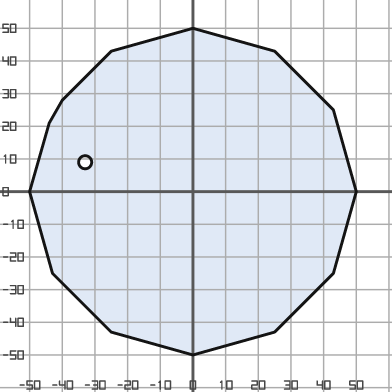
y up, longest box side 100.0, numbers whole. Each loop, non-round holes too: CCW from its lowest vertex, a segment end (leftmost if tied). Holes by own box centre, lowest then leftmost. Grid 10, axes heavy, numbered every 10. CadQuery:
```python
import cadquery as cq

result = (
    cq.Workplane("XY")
    .moveTo(0.0, -50.0)
    .lineTo(25.0, -43.0)
    .lineTo(43.0, -25.0)
    .lineTo(50.0, 0.0)
    .lineTo(43.0, 25.0)
    .lineTo(25.0, 43.0)
    .lineTo(0.0, 50.0)
    .lineTo(-25.0, 43.0)
    .lineTo(-40.0, 28.0)
    .lineTo(-44.0, 21.0)
    .lineTo(-50.0, 0.0)
    .lineTo(-43.0, -25.0)
    .lineTo(-25.0, -43.0)
    .close()
    .moveTo(-33.0, 9.0)
    .circle(2.0)
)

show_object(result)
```